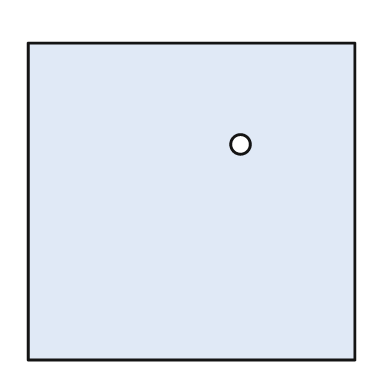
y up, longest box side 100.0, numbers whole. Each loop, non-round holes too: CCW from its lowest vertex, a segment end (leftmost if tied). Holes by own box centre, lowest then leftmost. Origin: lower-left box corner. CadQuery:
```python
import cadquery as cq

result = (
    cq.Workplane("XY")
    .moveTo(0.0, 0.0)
    .lineTo(100.0, 0.0)
    .lineTo(100.0, 97.0)
    .lineTo(0.0, 97.0)
    .close()
    .moveTo(65.0, 66.0)
    .circle(3.0)
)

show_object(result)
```